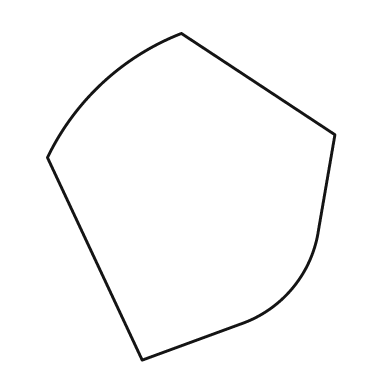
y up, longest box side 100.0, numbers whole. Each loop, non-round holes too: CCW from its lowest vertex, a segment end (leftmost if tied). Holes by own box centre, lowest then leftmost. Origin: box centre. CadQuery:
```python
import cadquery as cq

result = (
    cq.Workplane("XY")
    .moveTo(-15.0, -50.0)
    .lineTo(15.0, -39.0)
    .threePointArc((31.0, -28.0), (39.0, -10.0))
    .lineTo(44.0, 19.0)
    .lineTo(-3.0, 50.0)
    .threePointArc((-27.0, 35.0), (-44.0, 12.0))
    .close()
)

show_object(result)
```